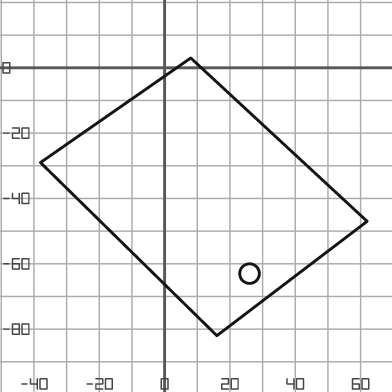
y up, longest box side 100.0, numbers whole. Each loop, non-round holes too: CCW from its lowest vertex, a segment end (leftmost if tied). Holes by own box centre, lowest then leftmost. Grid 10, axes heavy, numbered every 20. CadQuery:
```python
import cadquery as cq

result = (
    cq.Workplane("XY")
    .moveTo(16.0, -82.0)
    .lineTo(62.0, -47.0)
    .lineTo(8.0, 3.0)
    .lineTo(-38.0, -29.0)
    .close()
    .moveTo(26.0, -63.0)
    .circle(3.0)
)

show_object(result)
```